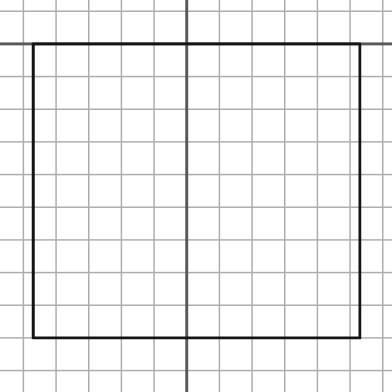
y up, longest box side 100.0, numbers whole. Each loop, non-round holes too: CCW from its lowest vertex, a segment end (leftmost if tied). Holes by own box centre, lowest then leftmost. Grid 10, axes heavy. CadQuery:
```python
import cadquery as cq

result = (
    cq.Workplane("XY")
    .moveTo(-47.0, -90.0)
    .lineTo(53.0, -90.0)
    .lineTo(53.0, 0.0)
    .lineTo(-47.0, 0.0)
    .close()
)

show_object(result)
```